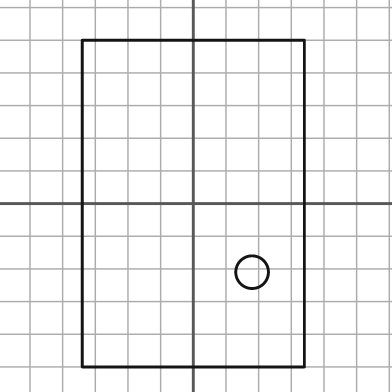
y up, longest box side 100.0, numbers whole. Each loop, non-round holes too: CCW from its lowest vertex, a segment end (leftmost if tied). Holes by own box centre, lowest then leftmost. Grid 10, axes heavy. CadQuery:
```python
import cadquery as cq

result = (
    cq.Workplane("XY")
    .moveTo(-34.0, -50.0)
    .lineTo(34.0, -50.0)
    .lineTo(34.0, 50.0)
    .lineTo(-34.0, 50.0)
    .close()
    .moveTo(18.0, -21.0)
    .circle(5.0)
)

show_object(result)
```